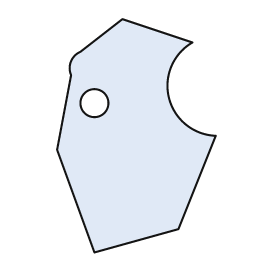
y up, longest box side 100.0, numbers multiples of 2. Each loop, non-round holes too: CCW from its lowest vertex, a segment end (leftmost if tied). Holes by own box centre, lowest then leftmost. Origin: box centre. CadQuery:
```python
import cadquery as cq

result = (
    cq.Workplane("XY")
    .moveTo(-18.0, -50.0)
    .lineTo(18.0, -40.0)
    .lineTo(34.0, 0.0)
    .threePointArc((14.0, 16.0), (24.0, 40.0))
    .lineTo(-6.0, 50.0)
    .lineTo(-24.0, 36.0)
    .threePointArc((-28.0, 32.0), (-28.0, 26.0))
    .lineTo(-34.0, -6.0)
    .close()
    .moveTo(-18.0, 14.0)
    .circle(6.0)
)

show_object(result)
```